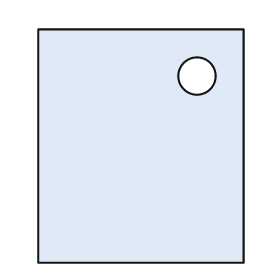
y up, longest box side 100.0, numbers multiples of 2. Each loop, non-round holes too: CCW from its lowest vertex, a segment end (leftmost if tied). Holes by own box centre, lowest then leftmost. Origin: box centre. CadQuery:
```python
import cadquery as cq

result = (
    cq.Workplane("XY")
    .moveTo(-44.0, -50.0)
    .lineTo(44.0, -50.0)
    .lineTo(44.0, 50.0)
    .lineTo(-44.0, 50.0)
    .close()
    .moveTo(24.0, 30.0)
    .circle(8.0)
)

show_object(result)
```